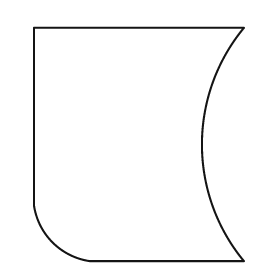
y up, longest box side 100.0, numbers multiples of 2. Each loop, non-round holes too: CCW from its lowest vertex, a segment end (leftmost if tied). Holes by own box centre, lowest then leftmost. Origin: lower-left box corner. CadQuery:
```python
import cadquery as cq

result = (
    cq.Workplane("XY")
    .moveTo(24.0, 0.0)
    .lineTo(90.0, 0.0)
    .threePointArc((72.0, 50.0), (90.0, 100.0))
    .lineTo(0.0, 100.0)
    .lineTo(0.0, 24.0)
    .threePointArc((8.0, 8.0), (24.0, 0.0))
    .close()
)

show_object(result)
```